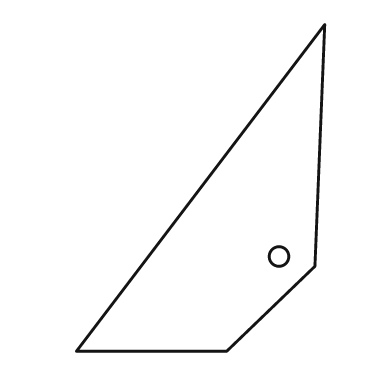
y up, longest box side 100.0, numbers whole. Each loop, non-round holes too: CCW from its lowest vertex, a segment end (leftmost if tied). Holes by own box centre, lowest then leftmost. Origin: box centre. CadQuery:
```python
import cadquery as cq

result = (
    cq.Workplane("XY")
    .moveTo(-38.0, -50.0)
    .lineTo(8.0, -50.0)
    .lineTo(35.0, -24.0)
    .lineTo(38.0, 50.0)
    .close()
    .moveTo(24.0, -21.0)
    .circle(3.0)
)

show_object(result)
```